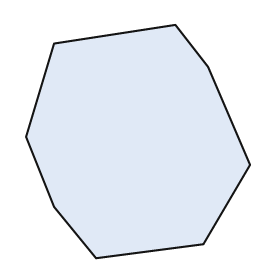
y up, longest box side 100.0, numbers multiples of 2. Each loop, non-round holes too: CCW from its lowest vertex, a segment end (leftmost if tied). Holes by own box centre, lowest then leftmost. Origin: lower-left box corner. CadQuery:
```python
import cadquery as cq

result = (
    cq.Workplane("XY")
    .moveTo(30.0, 0.0)
    .lineTo(76.0, 6.0)
    .lineTo(96.0, 40.0)
    .lineTo(78.0, 82.0)
    .lineTo(64.0, 100.0)
    .lineTo(12.0, 92.0)
    .lineTo(0.0, 52.0)
    .lineTo(12.0, 22.0)
    .close()
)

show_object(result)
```